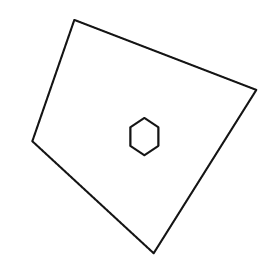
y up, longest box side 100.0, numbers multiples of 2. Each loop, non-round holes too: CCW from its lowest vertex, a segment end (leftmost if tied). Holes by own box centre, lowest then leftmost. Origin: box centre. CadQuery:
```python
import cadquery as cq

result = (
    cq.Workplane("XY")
    .moveTo(4.0, -50.0)
    .lineTo(48.0, 20.0)
    .lineTo(-30.0, 50.0)
    .lineTo(-48.0, -2.0)
    .close()
    .moveTo(0.0, -8.0)
    .lineTo(6.0, -4.0)
    .lineTo(6.0, 4.0)
    .lineTo(0.0, 8.0)
    .lineTo(-6.0, 4.0)
    .lineTo(-6.0, -4.0)
    .close()
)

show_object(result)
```